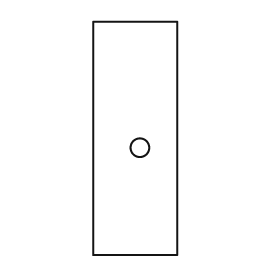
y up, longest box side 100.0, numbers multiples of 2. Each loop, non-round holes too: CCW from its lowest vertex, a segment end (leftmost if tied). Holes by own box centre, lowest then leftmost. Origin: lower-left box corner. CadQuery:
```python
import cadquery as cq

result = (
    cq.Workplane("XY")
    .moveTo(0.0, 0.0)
    .lineTo(36.0, 0.0)
    .lineTo(36.0, 100.0)
    .lineTo(0.0, 100.0)
    .close()
    .moveTo(20.0, 46.0)
    .circle(4.0)
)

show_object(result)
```